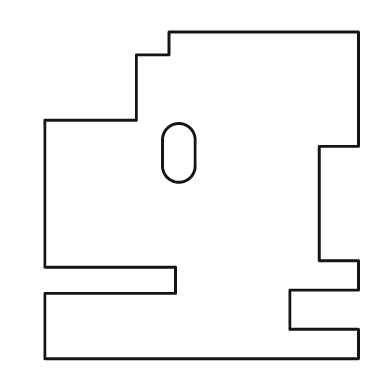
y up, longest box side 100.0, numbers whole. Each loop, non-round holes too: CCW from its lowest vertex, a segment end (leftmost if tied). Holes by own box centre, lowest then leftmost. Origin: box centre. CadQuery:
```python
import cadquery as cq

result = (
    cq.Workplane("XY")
    .moveTo(-48.0, -50.0)
    .lineTo(48.0, -50.0)
    .lineTo(48.0, -41.0)
    .lineTo(27.0, -41.0)
    .lineTo(27.0, -29.0)
    .lineTo(48.0, -29.0)
    .lineTo(48.0, -20.0)
    .lineTo(36.0, -20.0)
    .lineTo(36.0, 15.0)
    .lineTo(48.0, 15.0)
    .lineTo(48.0, 50.0)
    .lineTo(-10.0, 50.0)
    .lineTo(-10.0, 43.0)
    .lineTo(-20.0, 43.0)
    .lineTo(-20.0, 23.0)
    .lineTo(-48.0, 23.0)
    .lineTo(-48.0, -22.0)
    .lineTo(-8.0, -22.0)
    .lineTo(-8.0, -30.0)
    .lineTo(-48.0, -30.0)
    .close()
    .moveTo(-12.0, 9.0)
    .threePointArc((-7.0, 4.0), (-2.0, 9.0))
    .lineTo(-2.0, 17.0)
    .threePointArc((-7.0, 22.0), (-12.0, 17.0))
    .close()
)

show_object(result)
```